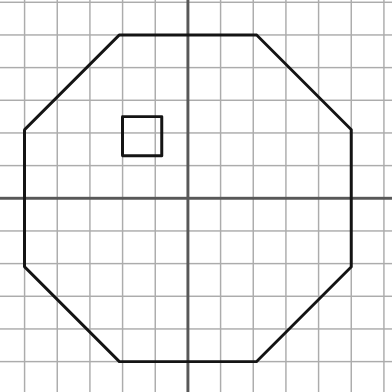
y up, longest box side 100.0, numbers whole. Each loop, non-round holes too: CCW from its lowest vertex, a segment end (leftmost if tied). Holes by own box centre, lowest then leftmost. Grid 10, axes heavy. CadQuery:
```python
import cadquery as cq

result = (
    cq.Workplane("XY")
    .moveTo(-21.0, -50.0)
    .lineTo(21.0, -50.0)
    .lineTo(50.0, -21.0)
    .lineTo(50.0, 21.0)
    .lineTo(21.0, 50.0)
    .lineTo(-21.0, 50.0)
    .lineTo(-50.0, 21.0)
    .lineTo(-50.0, -21.0)
    .close()
    .moveTo(-20.0, 13.0)
    .lineTo(-8.0, 13.0)
    .lineTo(-8.0, 25.0)
    .lineTo(-20.0, 25.0)
    .close()
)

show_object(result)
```